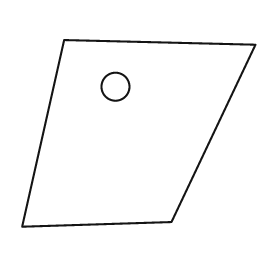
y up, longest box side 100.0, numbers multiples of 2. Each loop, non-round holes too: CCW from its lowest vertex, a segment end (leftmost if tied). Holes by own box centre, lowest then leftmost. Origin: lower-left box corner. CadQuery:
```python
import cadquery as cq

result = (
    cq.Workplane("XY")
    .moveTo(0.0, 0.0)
    .lineTo(64.0, 2.0)
    .lineTo(100.0, 78.0)
    .lineTo(18.0, 80.0)
    .close()
    .moveTo(40.0, 60.0)
    .circle(6.0)
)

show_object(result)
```